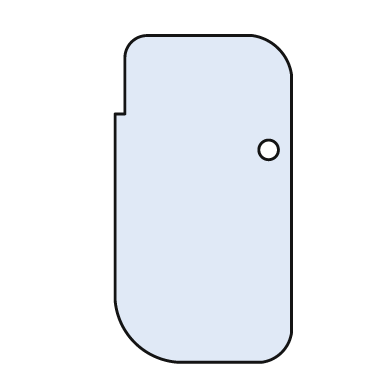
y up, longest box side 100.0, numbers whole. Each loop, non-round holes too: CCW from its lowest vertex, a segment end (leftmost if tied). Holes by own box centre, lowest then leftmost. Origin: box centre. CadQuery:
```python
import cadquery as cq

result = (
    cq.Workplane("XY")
    .moveTo(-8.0, -50.0)
    .lineTo(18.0, -50.0)
    .threePointArc((24.0, -47.0), (27.0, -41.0))
    .lineTo(27.0, 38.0)
    .threePointArc((23.0, 46.0), (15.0, 50.0))
    .lineTo(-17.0, 50.0)
    .threePointArc((-22.0, 48.0), (-24.0, 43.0))
    .lineTo(-24.0, 26.0)
    .lineTo(-27.0, 26.0)
    .lineTo(-27.0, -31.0)
    .threePointArc((-21.0, -44.0), (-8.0, -50.0))
    .close()
    .moveTo(20.0, 15.0)
    .circle(3.0)
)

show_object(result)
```